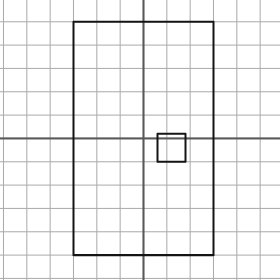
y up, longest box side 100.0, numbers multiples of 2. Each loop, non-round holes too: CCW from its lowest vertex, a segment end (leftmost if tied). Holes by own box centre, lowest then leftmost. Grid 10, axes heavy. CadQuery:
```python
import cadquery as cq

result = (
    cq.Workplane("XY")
    .moveTo(-30.0, -50.0)
    .lineTo(30.0, -50.0)
    .lineTo(30.0, 50.0)
    .lineTo(-30.0, 50.0)
    .close()
    .moveTo(6.0, -10.0)
    .lineTo(18.0, -10.0)
    .lineTo(18.0, 2.0)
    .lineTo(6.0, 2.0)
    .close()
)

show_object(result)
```